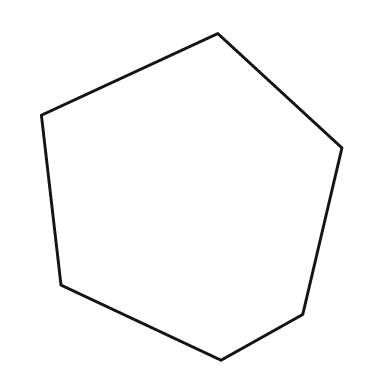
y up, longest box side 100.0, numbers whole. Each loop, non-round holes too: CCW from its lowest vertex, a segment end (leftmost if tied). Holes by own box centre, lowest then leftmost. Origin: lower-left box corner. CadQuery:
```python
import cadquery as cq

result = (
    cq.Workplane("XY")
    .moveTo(55.0, 0.0)
    .lineTo(80.0, 14.0)
    .lineTo(92.0, 65.0)
    .lineTo(54.0, 100.0)
    .lineTo(0.0, 75.0)
    .lineTo(6.0, 23.0)
    .close()
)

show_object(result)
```